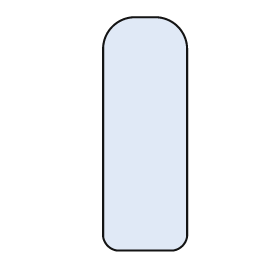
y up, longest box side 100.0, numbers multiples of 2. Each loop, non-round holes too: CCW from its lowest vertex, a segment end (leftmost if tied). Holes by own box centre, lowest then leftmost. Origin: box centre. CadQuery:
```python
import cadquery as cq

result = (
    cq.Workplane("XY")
    .moveTo(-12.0, -50.0)
    .lineTo(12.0, -50.0)
    .threePointArc((16.0, -48.0), (18.0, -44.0))
    .lineTo(18.0, 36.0)
    .threePointArc((14.0, 46.0), (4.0, 50.0))
    .lineTo(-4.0, 50.0)
    .threePointArc((-14.0, 46.0), (-18.0, 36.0))
    .lineTo(-18.0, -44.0)
    .threePointArc((-16.0, -48.0), (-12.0, -50.0))
    .close()
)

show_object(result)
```